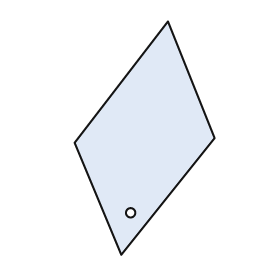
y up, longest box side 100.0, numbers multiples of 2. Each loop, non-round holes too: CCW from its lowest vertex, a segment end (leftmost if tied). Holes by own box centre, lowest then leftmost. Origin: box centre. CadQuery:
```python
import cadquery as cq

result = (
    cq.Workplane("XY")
    .moveTo(-10.0, -50.0)
    .lineTo(30.0, 0.0)
    .lineTo(10.0, 50.0)
    .lineTo(-30.0, -2.0)
    .close()
    .moveTo(-6.0, -32.0)
    .circle(2.0)
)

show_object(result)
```